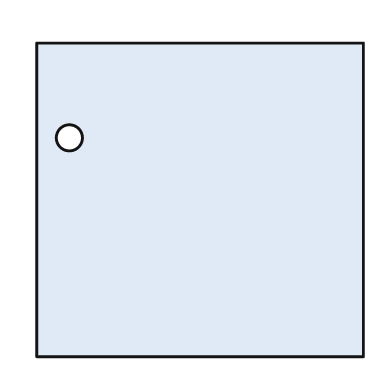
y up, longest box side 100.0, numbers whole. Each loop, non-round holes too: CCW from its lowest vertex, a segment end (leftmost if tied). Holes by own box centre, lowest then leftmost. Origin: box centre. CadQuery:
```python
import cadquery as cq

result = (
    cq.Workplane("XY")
    .moveTo(-50.0, -48.0)
    .lineTo(50.0, -48.0)
    .lineTo(50.0, 48.0)
    .lineTo(-50.0, 48.0)
    .close()
    .moveTo(-40.0, 19.0)
    .circle(4.0)
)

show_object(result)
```